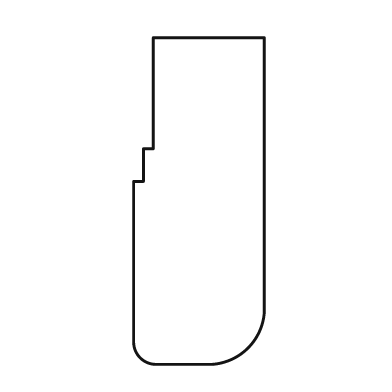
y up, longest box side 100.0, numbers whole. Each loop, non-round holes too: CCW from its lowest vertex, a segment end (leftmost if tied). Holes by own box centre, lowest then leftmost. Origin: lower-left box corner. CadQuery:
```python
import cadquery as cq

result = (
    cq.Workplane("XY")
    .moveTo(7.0, 0.0)
    .lineTo(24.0, 0.0)
    .threePointArc((35.0, 5.0), (40.0, 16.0))
    .lineTo(40.0, 100.0)
    .lineTo(6.0, 100.0)
    .lineTo(6.0, 66.0)
    .lineTo(3.0, 66.0)
    .lineTo(3.0, 56.0)
    .lineTo(0.0, 56.0)
    .lineTo(0.0, 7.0)
    .threePointArc((2.0, 2.0), (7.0, 0.0))
    .close()
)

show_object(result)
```